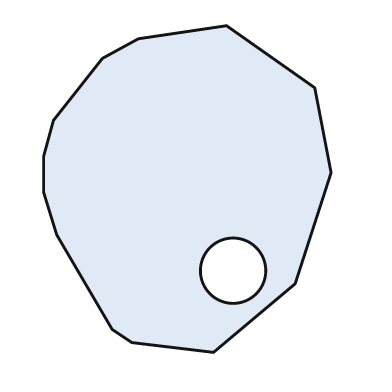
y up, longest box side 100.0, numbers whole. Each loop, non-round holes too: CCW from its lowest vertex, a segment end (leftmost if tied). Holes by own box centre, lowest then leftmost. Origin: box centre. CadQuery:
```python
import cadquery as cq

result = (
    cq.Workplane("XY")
    .moveTo(8.0, -50.0)
    .lineTo(33.0, -29.0)
    .lineTo(44.0, 5.0)
    .lineTo(39.0, 31.0)
    .lineTo(12.0, 50.0)
    .lineTo(-15.0, 46.0)
    .lineTo(-26.0, 40.0)
    .lineTo(-41.0, 21.0)
    .lineTo(-44.0, 10.0)
    .lineTo(-44.0, -1.0)
    .lineTo(-40.0, -14.0)
    .lineTo(-23.0, -43.0)
    .lineTo(-17.0, -47.0)
    .close()
    .moveTo(14.0, -25.0)
    .circle(10.0)
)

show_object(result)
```